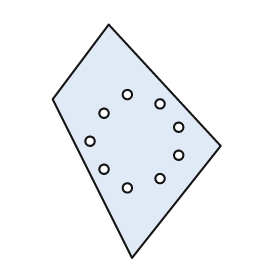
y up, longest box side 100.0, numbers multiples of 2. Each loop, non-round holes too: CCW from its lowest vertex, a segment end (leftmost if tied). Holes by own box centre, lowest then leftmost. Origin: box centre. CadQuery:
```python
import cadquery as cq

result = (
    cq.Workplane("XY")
    .moveTo(-2.0, -50.0)
    .lineTo(36.0, -2.0)
    .lineTo(-12.0, 50.0)
    .lineTo(-36.0, 18.0)
    .close()
    .moveTo(-4.0, -20.0)
    .circle(2.0)
    .moveTo(10.0, -16.0)
    .circle(2.0)
    .moveTo(-14.0, -12.0)
    .circle(2.0)
    .moveTo(18.0, -6.0)
    .circle(2.0)
    .moveTo(-20.0, 0.0)
    .circle(2.0)
    .moveTo(18.0, 6.0)
    .circle(2.0)
    .moveTo(-14.0, 12.0)
    .circle(2.0)
    .moveTo(10.0, 16.0)
    .circle(2.0)
    .moveTo(-4.0, 20.0)
    .circle(2.0)
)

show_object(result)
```